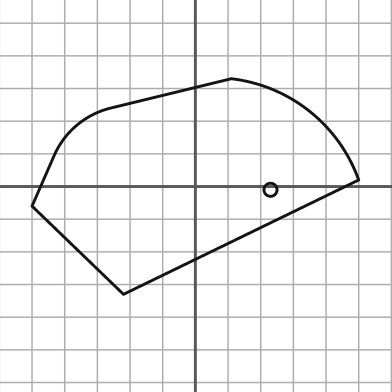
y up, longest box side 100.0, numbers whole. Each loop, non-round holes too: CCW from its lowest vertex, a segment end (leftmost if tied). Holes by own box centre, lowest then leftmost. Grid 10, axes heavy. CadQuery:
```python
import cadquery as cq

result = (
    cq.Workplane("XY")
    .moveTo(-22.0, -33.0)
    .lineTo(50.0, 2.0)
    .threePointArc((35.0, 23.0), (11.0, 33.0))
    .lineTo(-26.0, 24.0)
    .threePointArc((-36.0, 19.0), (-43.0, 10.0))
    .lineTo(-50.0, -6.0)
    .close()
    .moveTo(23.0, -1.0)
    .circle(2.0)
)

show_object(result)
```